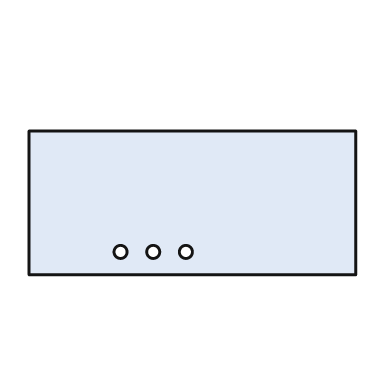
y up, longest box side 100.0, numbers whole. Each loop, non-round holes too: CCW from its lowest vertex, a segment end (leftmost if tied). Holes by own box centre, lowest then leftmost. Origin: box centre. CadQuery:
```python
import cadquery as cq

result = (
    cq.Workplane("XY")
    .moveTo(-50.0, -22.0)
    .lineTo(50.0, -22.0)
    .lineTo(50.0, 22.0)
    .lineTo(-50.0, 22.0)
    .close()
    .moveTo(-22.0, -15.0)
    .circle(2.0)
    .moveTo(-12.0, -15.0)
    .circle(2.0)
    .moveTo(-2.0, -15.0)
    .circle(2.0)
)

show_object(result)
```